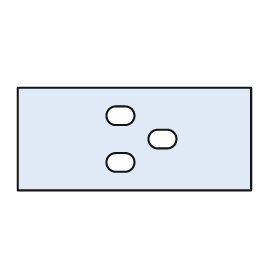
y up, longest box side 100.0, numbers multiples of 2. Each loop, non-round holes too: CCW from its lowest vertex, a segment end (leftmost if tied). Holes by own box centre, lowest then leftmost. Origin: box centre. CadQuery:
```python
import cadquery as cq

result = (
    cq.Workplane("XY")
    .moveTo(-50.0, -22.0)
    .lineTo(50.0, -22.0)
    .lineTo(50.0, 22.0)
    .lineTo(-50.0, 22.0)
    .close()
    .moveTo(-8.0, -14.0)
    .lineTo(-4.0, -14.0)
    .threePointArc((0.0, -10.0), (-4.0, -6.0))
    .lineTo(-8.0, -6.0)
    .threePointArc((-12.0, -10.0), (-8.0, -14.0))
    .close()
    .moveTo(10.0, -4.0)
    .lineTo(14.0, -4.0)
    .threePointArc((18.0, 0.0), (14.0, 4.0))
    .lineTo(10.0, 4.0)
    .threePointArc((6.0, 0.0), (10.0, -4.0))
    .close()
    .moveTo(-8.0, 6.0)
    .lineTo(-4.0, 6.0)
    .threePointArc((0.0, 10.0), (-4.0, 14.0))
    .lineTo(-8.0, 14.0)
    .threePointArc((-12.0, 10.0), (-8.0, 6.0))
    .close()
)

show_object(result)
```